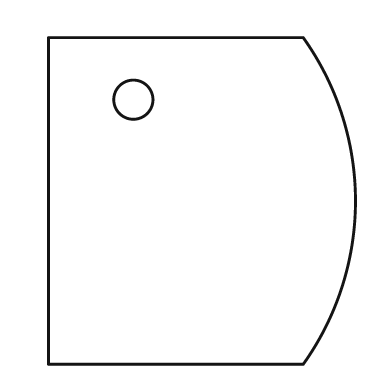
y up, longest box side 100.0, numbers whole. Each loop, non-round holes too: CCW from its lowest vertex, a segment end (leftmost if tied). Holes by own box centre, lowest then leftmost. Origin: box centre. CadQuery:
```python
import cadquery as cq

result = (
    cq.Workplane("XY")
    .moveTo(-47.0, -50.0)
    .lineTo(31.0, -50.0)
    .threePointArc((47.0, 0.0), (31.0, 50.0))
    .lineTo(-47.0, 50.0)
    .close()
    .moveTo(-21.0, 31.0)
    .circle(6.0)
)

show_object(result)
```